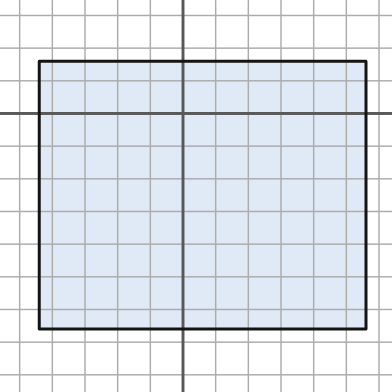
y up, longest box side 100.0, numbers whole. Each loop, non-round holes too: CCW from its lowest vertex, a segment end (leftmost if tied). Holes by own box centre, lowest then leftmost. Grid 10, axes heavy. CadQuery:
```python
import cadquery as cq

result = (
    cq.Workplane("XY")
    .moveTo(-44.0, -66.0)
    .lineTo(56.0, -66.0)
    .lineTo(56.0, 16.0)
    .lineTo(-44.0, 16.0)
    .close()
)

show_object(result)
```